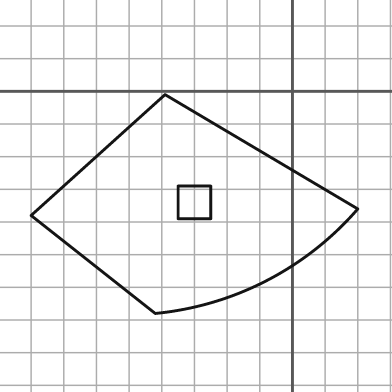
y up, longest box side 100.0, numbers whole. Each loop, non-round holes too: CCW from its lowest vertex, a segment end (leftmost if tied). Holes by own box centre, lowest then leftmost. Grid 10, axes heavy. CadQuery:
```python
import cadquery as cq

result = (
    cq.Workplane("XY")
    .moveTo(-42.0, -68.0)
    .threePointArc((-8.0, -58.0), (20.0, -36.0))
    .lineTo(-39.0, -1.0)
    .lineTo(-80.0, -38.0)
    .close()
    .moveTo(-35.0, -39.0)
    .lineTo(-25.0, -39.0)
    .lineTo(-25.0, -29.0)
    .lineTo(-35.0, -29.0)
    .close()
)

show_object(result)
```